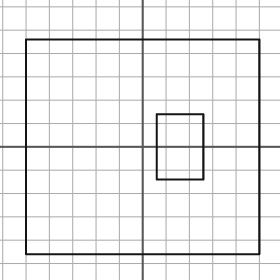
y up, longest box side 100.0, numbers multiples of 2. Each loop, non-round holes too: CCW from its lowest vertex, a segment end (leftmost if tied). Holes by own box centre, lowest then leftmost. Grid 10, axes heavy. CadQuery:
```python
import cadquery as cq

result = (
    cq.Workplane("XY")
    .moveTo(-50.0, -46.0)
    .lineTo(50.0, -46.0)
    .lineTo(50.0, 46.0)
    .lineTo(-50.0, 46.0)
    .close()
    .moveTo(6.0, -14.0)
    .lineTo(26.0, -14.0)
    .lineTo(26.0, 14.0)
    .lineTo(6.0, 14.0)
    .close()
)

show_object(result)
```